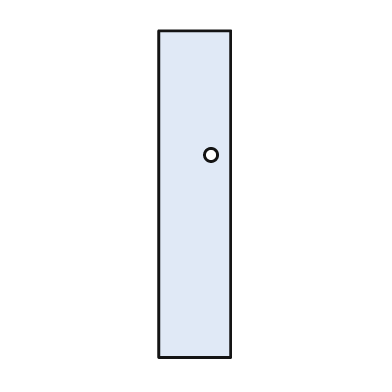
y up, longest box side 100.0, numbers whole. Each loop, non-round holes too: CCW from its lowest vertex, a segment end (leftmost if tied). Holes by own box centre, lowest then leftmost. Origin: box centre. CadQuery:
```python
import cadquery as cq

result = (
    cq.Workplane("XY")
    .moveTo(-11.0, -50.0)
    .lineTo(11.0, -50.0)
    .lineTo(11.0, 50.0)
    .lineTo(-11.0, 50.0)
    .close()
    .moveTo(5.0, 12.0)
    .circle(2.0)
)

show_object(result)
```